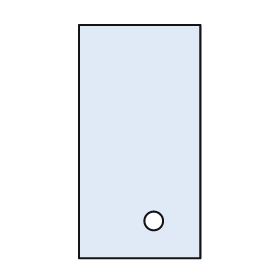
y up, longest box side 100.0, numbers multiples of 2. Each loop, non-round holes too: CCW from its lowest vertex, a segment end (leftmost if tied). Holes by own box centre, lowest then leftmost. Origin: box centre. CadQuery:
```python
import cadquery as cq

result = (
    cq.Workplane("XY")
    .moveTo(-26.0, -50.0)
    .lineTo(26.0, -50.0)
    .lineTo(26.0, 50.0)
    .lineTo(-26.0, 50.0)
    .close()
    .moveTo(6.0, -34.0)
    .circle(4.0)
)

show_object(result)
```